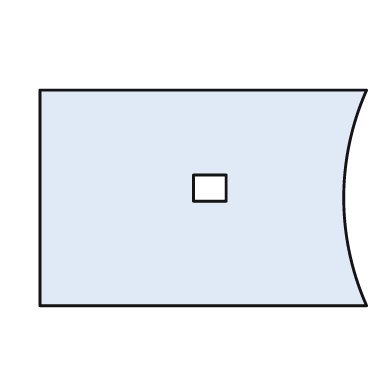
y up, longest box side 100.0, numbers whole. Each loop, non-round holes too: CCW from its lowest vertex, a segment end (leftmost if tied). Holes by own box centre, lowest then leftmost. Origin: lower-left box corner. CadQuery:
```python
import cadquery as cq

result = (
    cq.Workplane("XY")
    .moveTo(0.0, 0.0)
    .lineTo(100.0, 0.0)
    .threePointArc((93.0, 33.0), (100.0, 66.0))
    .lineTo(0.0, 66.0)
    .close()
    .moveTo(47.0, 32.0)
    .lineTo(57.0, 32.0)
    .lineTo(57.0, 40.0)
    .lineTo(47.0, 40.0)
    .close()
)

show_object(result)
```